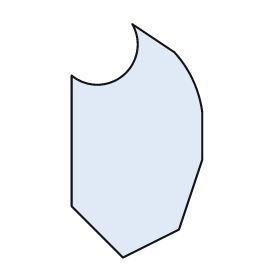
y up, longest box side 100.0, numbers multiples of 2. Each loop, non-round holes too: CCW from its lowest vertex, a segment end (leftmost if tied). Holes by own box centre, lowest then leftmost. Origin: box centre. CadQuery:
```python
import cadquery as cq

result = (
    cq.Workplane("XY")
    .moveTo(-6.0, -50.0)
    .lineTo(18.0, -38.0)
    .lineTo(28.0, -8.0)
    .lineTo(28.0, 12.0)
    .threePointArc((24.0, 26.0), (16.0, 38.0))
    .lineTo(-2.0, 50.0)
    .threePointArc((-6.0, 28.0), (-28.0, 28.0))
    .lineTo(-28.0, -28.0)
    .close()
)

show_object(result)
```